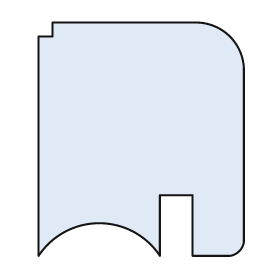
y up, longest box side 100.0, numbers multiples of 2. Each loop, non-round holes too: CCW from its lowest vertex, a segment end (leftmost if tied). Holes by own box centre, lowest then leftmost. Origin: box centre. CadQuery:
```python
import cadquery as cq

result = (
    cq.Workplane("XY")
    .moveTo(-44.0, -50.0)
    .threePointArc((-18.0, -36.0), (8.0, -50.0))
    .lineTo(8.0, -24.0)
    .lineTo(22.0, -24.0)
    .lineTo(22.0, -50.0)
    .lineTo(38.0, -50.0)
    .threePointArc((42.0, -48.0), (44.0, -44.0))
    .lineTo(44.0, 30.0)
    .threePointArc((38.0, 44.0), (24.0, 50.0))
    .lineTo(-38.0, 50.0)
    .lineTo(-38.0, 44.0)
    .lineTo(-44.0, 44.0)
    .close()
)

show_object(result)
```